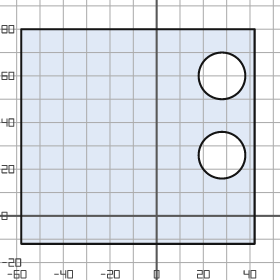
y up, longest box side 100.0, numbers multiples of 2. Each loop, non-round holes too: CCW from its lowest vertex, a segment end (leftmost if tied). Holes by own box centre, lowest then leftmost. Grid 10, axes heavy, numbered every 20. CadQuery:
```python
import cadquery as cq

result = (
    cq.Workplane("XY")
    .moveTo(-58.0, -12.0)
    .lineTo(42.0, -12.0)
    .lineTo(42.0, 80.0)
    .lineTo(-58.0, 80.0)
    .close()
    .moveTo(28.0, 26.0)
    .circle(10.0)
    .moveTo(28.0, 60.0)
    .circle(10.0)
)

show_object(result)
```